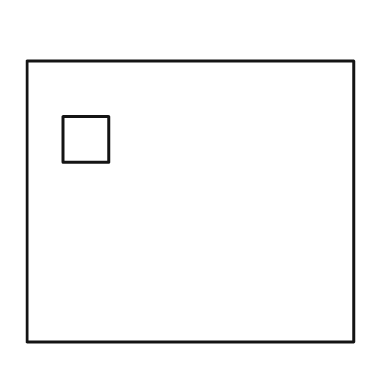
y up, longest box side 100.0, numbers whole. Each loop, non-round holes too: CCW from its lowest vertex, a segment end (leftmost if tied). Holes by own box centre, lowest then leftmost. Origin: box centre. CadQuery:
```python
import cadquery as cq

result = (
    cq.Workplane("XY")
    .moveTo(-50.0, -43.0)
    .lineTo(50.0, -43.0)
    .lineTo(50.0, 43.0)
    .lineTo(-50.0, 43.0)
    .close()
    .moveTo(-39.0, 12.0)
    .lineTo(-25.0, 12.0)
    .lineTo(-25.0, 26.0)
    .lineTo(-39.0, 26.0)
    .close()
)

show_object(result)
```